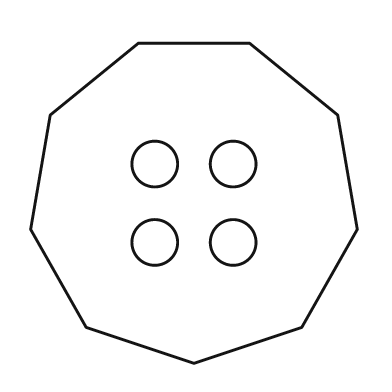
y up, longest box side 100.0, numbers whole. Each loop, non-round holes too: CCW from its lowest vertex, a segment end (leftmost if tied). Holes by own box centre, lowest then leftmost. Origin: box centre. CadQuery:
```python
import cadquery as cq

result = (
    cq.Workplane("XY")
    .moveTo(0.0, -49.0)
    .lineTo(33.0, -38.0)
    .lineTo(50.0, -8.0)
    .lineTo(44.0, 27.0)
    .lineTo(17.0, 49.0)
    .lineTo(-17.0, 49.0)
    .lineTo(-44.0, 27.0)
    .lineTo(-50.0, -8.0)
    .lineTo(-33.0, -38.0)
    .close()
    .moveTo(-12.0, -12.0)
    .circle(7.0)
    .moveTo(12.0, -12.0)
    .circle(7.0)
    .moveTo(-12.0, 12.0)
    .circle(7.0)
    .moveTo(12.0, 12.0)
    .circle(7.0)
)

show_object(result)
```